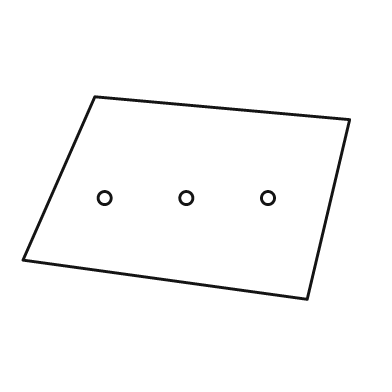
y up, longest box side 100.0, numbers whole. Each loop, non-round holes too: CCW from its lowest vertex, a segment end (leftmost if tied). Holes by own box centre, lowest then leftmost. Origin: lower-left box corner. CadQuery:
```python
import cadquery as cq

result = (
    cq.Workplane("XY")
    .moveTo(87.0, 0.0)
    .lineTo(100.0, 55.0)
    .lineTo(22.0, 62.0)
    .lineTo(0.0, 12.0)
    .close()
    .moveTo(25.0, 31.0)
    .circle(2.0)
    .moveTo(50.0, 31.0)
    .circle(2.0)
    .moveTo(75.0, 31.0)
    .circle(2.0)
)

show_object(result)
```